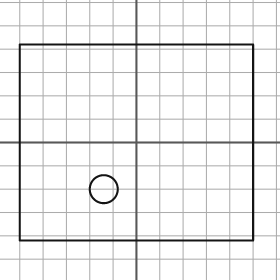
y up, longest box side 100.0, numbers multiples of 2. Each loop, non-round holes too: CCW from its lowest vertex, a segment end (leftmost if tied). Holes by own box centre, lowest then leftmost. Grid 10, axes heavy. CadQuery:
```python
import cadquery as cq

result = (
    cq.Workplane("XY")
    .moveTo(-50.0, -42.0)
    .lineTo(50.0, -42.0)
    .lineTo(50.0, 42.0)
    .lineTo(-50.0, 42.0)
    .close()
    .moveTo(-14.0, -20.0)
    .circle(6.0)
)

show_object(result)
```